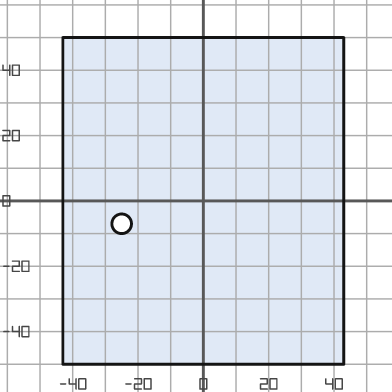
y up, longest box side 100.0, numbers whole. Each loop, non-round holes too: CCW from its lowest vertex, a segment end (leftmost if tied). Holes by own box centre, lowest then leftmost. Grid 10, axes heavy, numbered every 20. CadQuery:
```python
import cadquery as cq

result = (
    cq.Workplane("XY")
    .moveTo(-43.0, -50.0)
    .lineTo(43.0, -50.0)
    .lineTo(43.0, 50.0)
    .lineTo(-43.0, 50.0)
    .close()
    .moveTo(-25.0, -7.0)
    .circle(3.0)
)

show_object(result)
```